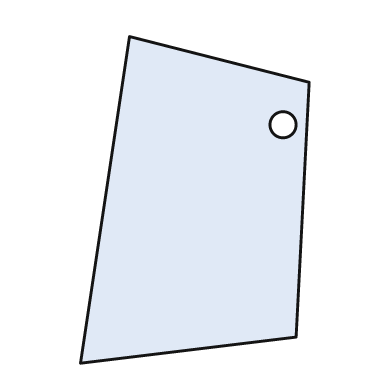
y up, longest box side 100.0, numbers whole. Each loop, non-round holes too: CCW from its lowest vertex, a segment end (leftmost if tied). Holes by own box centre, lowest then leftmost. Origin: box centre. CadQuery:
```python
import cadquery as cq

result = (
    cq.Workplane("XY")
    .moveTo(-35.0, -50.0)
    .lineTo(31.0, -42.0)
    .lineTo(35.0, 36.0)
    .lineTo(-20.0, 50.0)
    .close()
    .moveTo(27.0, 23.0)
    .circle(4.0)
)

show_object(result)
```